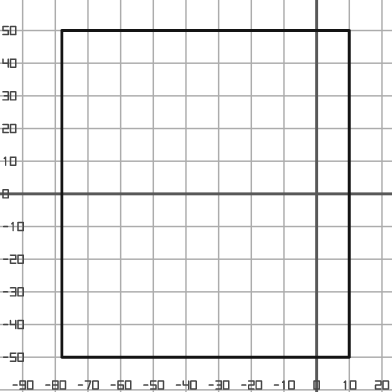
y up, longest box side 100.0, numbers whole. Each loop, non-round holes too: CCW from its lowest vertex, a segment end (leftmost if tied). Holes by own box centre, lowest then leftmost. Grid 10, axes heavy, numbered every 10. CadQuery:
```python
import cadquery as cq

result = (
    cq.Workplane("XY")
    .moveTo(-78.0, -50.0)
    .lineTo(10.0, -50.0)
    .lineTo(10.0, 50.0)
    .lineTo(-78.0, 50.0)
    .close()
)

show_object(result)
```